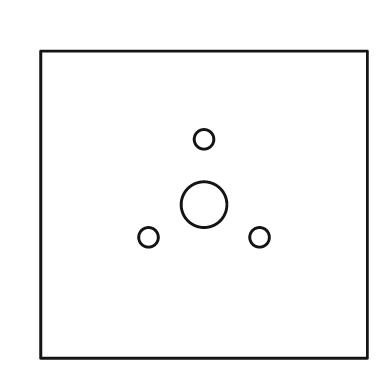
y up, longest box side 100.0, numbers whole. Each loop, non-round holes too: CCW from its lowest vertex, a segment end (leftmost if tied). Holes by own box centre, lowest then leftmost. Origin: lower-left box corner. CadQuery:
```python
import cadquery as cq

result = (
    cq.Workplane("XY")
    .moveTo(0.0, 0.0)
    .lineTo(100.0, 0.0)
    .lineTo(100.0, 94.0)
    .lineTo(0.0, 94.0)
    .close()
    .moveTo(33.0, 37.0)
    .circle(3.0)
    .moveTo(67.0, 37.0)
    .circle(3.0)
    .moveTo(50.0, 47.0)
    .circle(7.0)
    .moveTo(50.0, 67.0)
    .circle(3.0)
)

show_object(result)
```